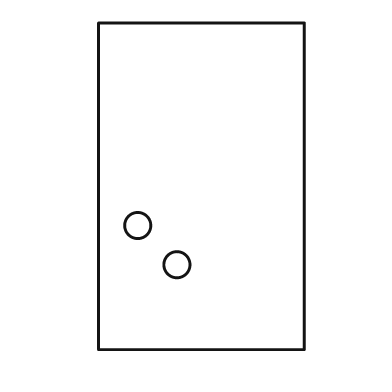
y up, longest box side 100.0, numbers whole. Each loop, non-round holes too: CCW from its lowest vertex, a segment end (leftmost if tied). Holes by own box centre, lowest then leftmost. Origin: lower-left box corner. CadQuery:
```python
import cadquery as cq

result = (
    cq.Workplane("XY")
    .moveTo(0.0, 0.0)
    .lineTo(63.0, 0.0)
    .lineTo(63.0, 100.0)
    .lineTo(0.0, 100.0)
    .close()
    .moveTo(24.0, 26.0)
    .circle(4.0)
    .moveTo(12.0, 38.0)
    .circle(4.0)
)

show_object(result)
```